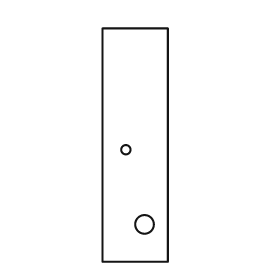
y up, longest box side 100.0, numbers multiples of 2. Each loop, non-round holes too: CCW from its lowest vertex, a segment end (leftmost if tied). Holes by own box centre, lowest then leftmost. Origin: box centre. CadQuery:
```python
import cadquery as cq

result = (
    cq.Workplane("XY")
    .moveTo(-14.0, -50.0)
    .lineTo(14.0, -50.0)
    .lineTo(14.0, 50.0)
    .lineTo(-14.0, 50.0)
    .close()
    .moveTo(4.0, -34.0)
    .circle(4.0)
    .moveTo(-4.0, -2.0)
    .circle(2.0)
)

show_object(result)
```